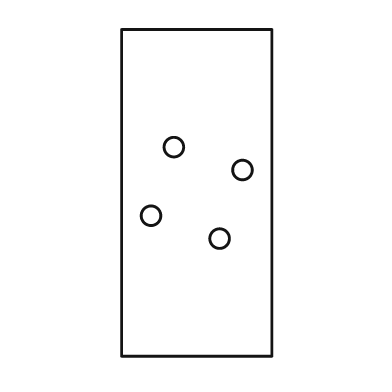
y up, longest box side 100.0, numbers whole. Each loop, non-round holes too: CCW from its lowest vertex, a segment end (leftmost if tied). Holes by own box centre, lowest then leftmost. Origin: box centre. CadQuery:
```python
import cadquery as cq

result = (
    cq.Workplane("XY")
    .moveTo(-23.0, -50.0)
    .lineTo(23.0, -50.0)
    .lineTo(23.0, 50.0)
    .lineTo(-23.0, 50.0)
    .close()
    .moveTo(7.0, -14.0)
    .circle(3.0)
    .moveTo(-14.0, -7.0)
    .circle(3.0)
    .moveTo(14.0, 7.0)
    .circle(3.0)
    .moveTo(-7.0, 14.0)
    .circle(3.0)
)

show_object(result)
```